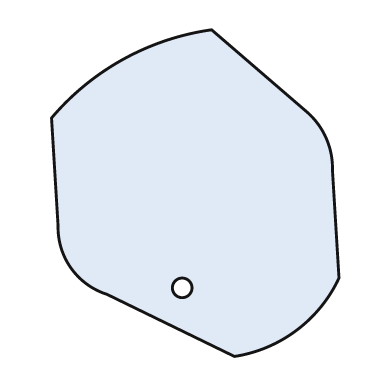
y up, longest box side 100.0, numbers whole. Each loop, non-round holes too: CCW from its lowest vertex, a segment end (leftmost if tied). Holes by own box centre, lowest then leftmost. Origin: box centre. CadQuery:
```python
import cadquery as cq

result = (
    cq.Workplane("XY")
    .moveTo(12.0, -50.0)
    .threePointArc((31.0, -42.0), (44.0, -26.0))
    .lineTo(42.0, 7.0)
    .threePointArc((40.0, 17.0), (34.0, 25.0))
    .lineTo(5.0, 50.0)
    .threePointArc((-22.0, 41.0), (-44.0, 23.0))
    .lineTo(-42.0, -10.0)
    .threePointArc((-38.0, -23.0), (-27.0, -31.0))
    .close()
    .moveTo(-4.0, -29.0)
    .circle(3.0)
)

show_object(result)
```